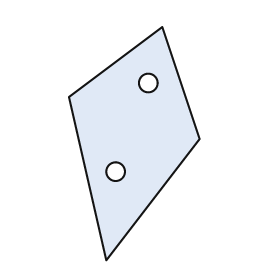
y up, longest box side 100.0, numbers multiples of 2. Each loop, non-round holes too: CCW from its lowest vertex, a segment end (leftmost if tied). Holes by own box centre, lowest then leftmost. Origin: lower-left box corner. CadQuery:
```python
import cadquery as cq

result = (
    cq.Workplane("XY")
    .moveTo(16.0, 0.0)
    .lineTo(56.0, 52.0)
    .lineTo(40.0, 100.0)
    .lineTo(0.0, 70.0)
    .close()
    .moveTo(20.0, 38.0)
    .circle(4.0)
    .moveTo(34.0, 76.0)
    .circle(4.0)
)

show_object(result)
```